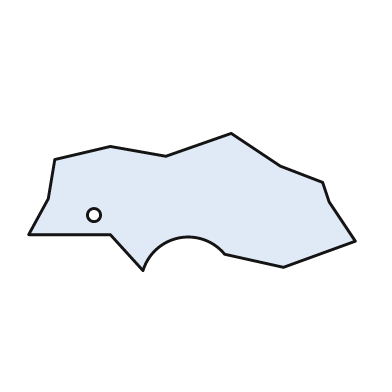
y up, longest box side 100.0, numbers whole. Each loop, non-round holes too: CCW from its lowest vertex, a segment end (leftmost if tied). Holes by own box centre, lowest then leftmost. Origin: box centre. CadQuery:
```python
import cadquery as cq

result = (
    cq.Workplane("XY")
    .moveTo(-15.0, -21.0)
    .threePointArc((-4.0, -11.0), (10.0, -16.0))
    .lineTo(28.0, -20.0)
    .lineTo(50.0, -12.0)
    .lineTo(42.0, 0.0)
    .lineTo(40.0, 6.0)
    .lineTo(27.0, 11.0)
    .lineTo(12.0, 21.0)
    .lineTo(-8.0, 14.0)
    .lineTo(-25.0, 17.0)
    .lineTo(-42.0, 13.0)
    .lineTo(-44.0, 1.0)
    .lineTo(-50.0, -10.0)
    .lineTo(-25.0, -10.0)
    .close()
    .moveTo(-30.0, -4.0)
    .circle(2.0)
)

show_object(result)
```